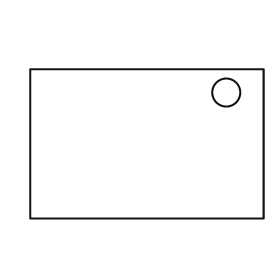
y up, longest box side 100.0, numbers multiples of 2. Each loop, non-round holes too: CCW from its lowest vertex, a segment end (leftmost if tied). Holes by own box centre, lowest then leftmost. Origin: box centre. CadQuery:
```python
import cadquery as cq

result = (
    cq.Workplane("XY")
    .moveTo(-50.0, -32.0)
    .lineTo(50.0, -32.0)
    .lineTo(50.0, 32.0)
    .lineTo(-50.0, 32.0)
    .close()
    .moveTo(34.0, 22.0)
    .circle(6.0)
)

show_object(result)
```